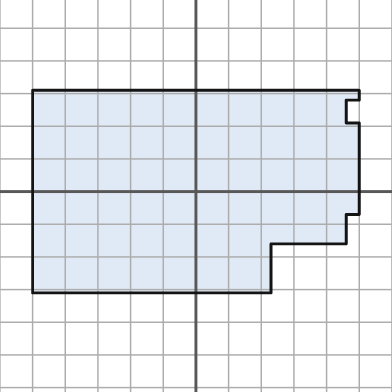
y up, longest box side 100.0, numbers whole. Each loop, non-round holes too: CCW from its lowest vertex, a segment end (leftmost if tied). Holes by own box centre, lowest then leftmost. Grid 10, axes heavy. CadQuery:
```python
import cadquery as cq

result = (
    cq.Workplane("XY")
    .moveTo(-50.0, -31.0)
    .lineTo(23.0, -31.0)
    .lineTo(23.0, -16.0)
    .lineTo(46.0, -16.0)
    .lineTo(46.0, -7.0)
    .lineTo(50.0, -7.0)
    .lineTo(50.0, 21.0)
    .lineTo(46.0, 21.0)
    .lineTo(46.0, 28.0)
    .lineTo(50.0, 28.0)
    .lineTo(50.0, 31.0)
    .lineTo(-50.0, 31.0)
    .close()
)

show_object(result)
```